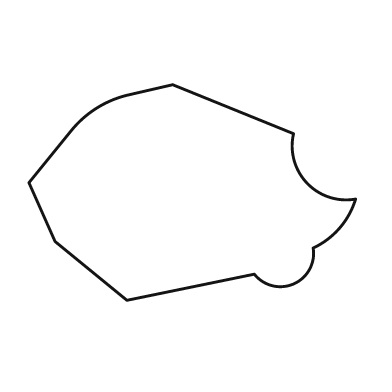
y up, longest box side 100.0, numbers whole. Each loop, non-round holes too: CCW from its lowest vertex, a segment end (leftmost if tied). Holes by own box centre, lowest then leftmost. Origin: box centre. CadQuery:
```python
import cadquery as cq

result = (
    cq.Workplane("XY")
    .moveTo(-20.0, -33.0)
    .lineTo(19.0, -25.0)
    .threePointArc((31.0, -28.0), (37.0, -17.0))
    .threePointArc((45.0, -11.0), (50.0, -2.0))
    .threePointArc((35.0, 3.0), (31.0, 18.0))
    .lineTo(-6.0, 33.0)
    .lineTo(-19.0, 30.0)
    .threePointArc((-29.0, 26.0), (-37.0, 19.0))
    .lineTo(-50.0, 3.0)
    .lineTo(-42.0, -15.0)
    .close()
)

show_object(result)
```